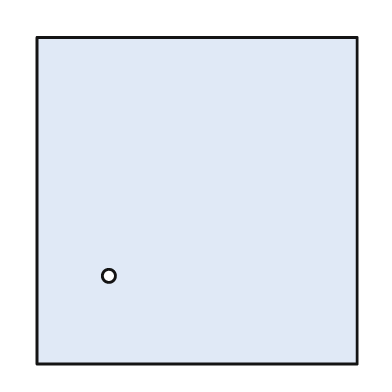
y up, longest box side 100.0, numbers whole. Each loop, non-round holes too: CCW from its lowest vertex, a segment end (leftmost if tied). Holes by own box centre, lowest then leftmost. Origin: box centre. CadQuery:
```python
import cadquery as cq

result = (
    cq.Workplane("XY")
    .moveTo(-49.0, -50.0)
    .lineTo(49.0, -50.0)
    .lineTo(49.0, 50.0)
    .lineTo(-49.0, 50.0)
    .close()
    .moveTo(-27.0, -23.0)
    .circle(2.0)
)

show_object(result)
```